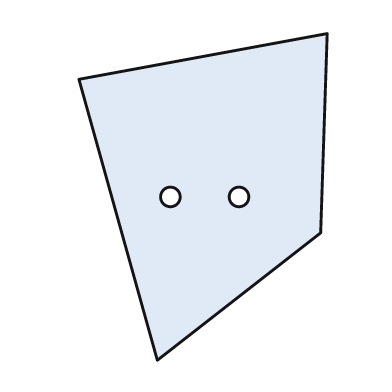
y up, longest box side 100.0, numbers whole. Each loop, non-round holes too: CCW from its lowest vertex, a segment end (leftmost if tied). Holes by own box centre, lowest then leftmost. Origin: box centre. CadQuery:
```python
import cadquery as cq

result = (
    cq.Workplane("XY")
    .moveTo(-14.0, -50.0)
    .lineTo(36.0, -11.0)
    .lineTo(38.0, 50.0)
    .lineTo(-38.0, 36.0)
    .close()
    .moveTo(-10.0, 0.0)
    .circle(3.0)
    .moveTo(11.0, 0.0)
    .circle(3.0)
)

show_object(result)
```